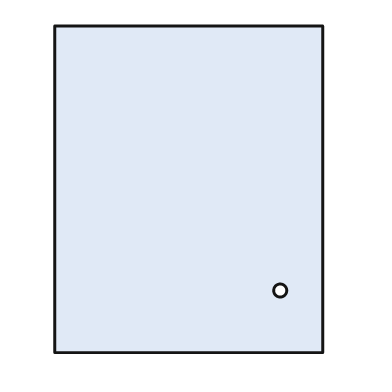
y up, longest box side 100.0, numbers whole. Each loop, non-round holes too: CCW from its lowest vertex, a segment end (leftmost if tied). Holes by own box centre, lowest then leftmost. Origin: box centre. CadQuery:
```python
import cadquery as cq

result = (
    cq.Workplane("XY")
    .moveTo(-41.0, -50.0)
    .lineTo(41.0, -50.0)
    .lineTo(41.0, 50.0)
    .lineTo(-41.0, 50.0)
    .close()
    .moveTo(28.0, -31.0)
    .circle(2.0)
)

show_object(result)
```